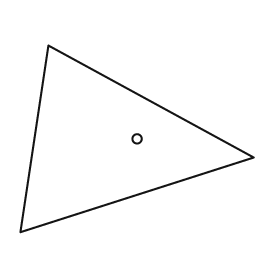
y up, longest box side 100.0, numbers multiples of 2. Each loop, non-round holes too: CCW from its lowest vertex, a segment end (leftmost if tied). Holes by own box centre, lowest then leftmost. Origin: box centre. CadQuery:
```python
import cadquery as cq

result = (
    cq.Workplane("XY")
    .moveTo(-50.0, -40.0)
    .lineTo(50.0, -8.0)
    .lineTo(-38.0, 40.0)
    .close()
    .moveTo(0.0, 0.0)
    .circle(2.0)
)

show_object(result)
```